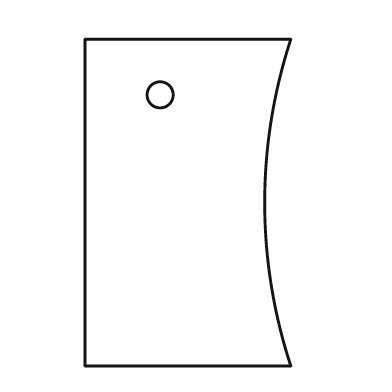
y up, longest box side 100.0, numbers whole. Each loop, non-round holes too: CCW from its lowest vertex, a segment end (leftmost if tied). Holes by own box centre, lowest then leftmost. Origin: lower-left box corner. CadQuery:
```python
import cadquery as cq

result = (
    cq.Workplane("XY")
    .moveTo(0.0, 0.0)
    .lineTo(63.0, 0.0)
    .threePointArc((55.0, 50.0), (63.0, 100.0))
    .lineTo(0.0, 100.0)
    .close()
    .moveTo(23.0, 83.0)
    .circle(4.0)
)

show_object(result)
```